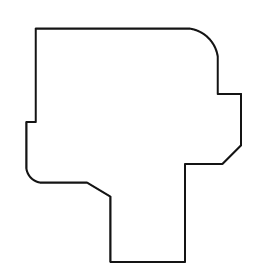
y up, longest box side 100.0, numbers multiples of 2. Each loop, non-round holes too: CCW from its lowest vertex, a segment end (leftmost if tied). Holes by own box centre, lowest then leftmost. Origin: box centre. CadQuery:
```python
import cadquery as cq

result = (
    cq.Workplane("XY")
    .moveTo(-10.0, -50.0)
    .lineTo(22.0, -50.0)
    .lineTo(22.0, -8.0)
    .lineTo(38.0, -8.0)
    .lineTo(46.0, 0.0)
    .lineTo(46.0, 22.0)
    .lineTo(36.0, 22.0)
    .lineTo(36.0, 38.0)
    .threePointArc((32.0, 46.0), (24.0, 50.0))
    .lineTo(-42.0, 50.0)
    .lineTo(-42.0, 10.0)
    .lineTo(-46.0, 10.0)
    .lineTo(-46.0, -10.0)
    .threePointArc((-44.0, -14.0), (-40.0, -16.0))
    .lineTo(-20.0, -16.0)
    .lineTo(-10.0, -22.0)
    .close()
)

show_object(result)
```